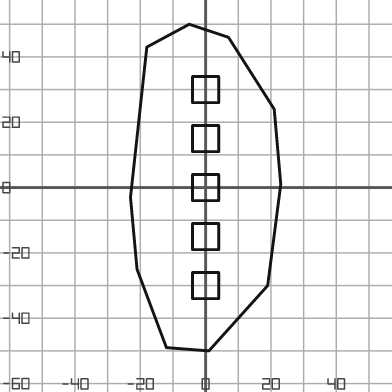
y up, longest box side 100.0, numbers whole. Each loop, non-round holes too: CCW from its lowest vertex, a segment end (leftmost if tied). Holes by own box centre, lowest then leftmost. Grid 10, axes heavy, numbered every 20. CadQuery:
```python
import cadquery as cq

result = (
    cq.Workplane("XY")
    .moveTo(1.0, -50.0)
    .lineTo(19.0, -30.0)
    .lineTo(23.0, 1.0)
    .lineTo(21.0, 24.0)
    .lineTo(7.0, 46.0)
    .lineTo(-5.0, 50.0)
    .lineTo(-18.0, 43.0)
    .lineTo(-23.0, -3.0)
    .lineTo(-21.0, -25.0)
    .lineTo(-12.0, -49.0)
    .close()
    .moveTo(-4.0, -34.0)
    .lineTo(4.0, -34.0)
    .lineTo(4.0, -26.0)
    .lineTo(-4.0, -26.0)
    .close()
    .moveTo(-4.0, -19.0)
    .lineTo(4.0, -19.0)
    .lineTo(4.0, -11.0)
    .lineTo(-4.0, -11.0)
    .close()
    .moveTo(-4.0, -4.0)
    .lineTo(4.0, -4.0)
    .lineTo(4.0, 4.0)
    .lineTo(-4.0, 4.0)
    .close()
    .moveTo(-4.0, 11.0)
    .lineTo(4.0, 11.0)
    .lineTo(4.0, 19.0)
    .lineTo(-4.0, 19.0)
    .close()
    .moveTo(-4.0, 26.0)
    .lineTo(4.0, 26.0)
    .lineTo(4.0, 34.0)
    .lineTo(-4.0, 34.0)
    .close()
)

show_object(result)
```